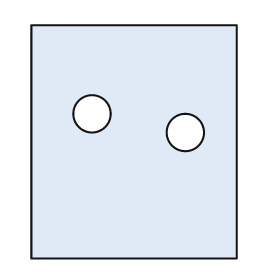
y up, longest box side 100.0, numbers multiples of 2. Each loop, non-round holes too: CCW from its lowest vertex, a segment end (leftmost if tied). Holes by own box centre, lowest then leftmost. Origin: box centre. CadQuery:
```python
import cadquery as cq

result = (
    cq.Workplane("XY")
    .moveTo(-44.0, -50.0)
    .lineTo(44.0, -50.0)
    .lineTo(44.0, 50.0)
    .lineTo(-44.0, 50.0)
    .close()
    .moveTo(22.0, 4.0)
    .circle(8.0)
    .moveTo(-18.0, 12.0)
    .circle(8.0)
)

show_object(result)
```